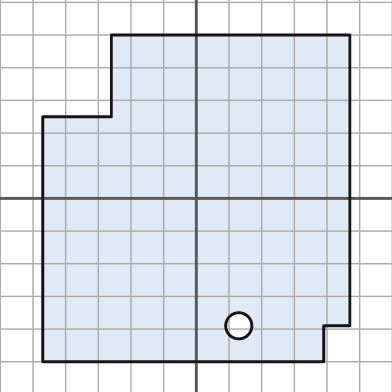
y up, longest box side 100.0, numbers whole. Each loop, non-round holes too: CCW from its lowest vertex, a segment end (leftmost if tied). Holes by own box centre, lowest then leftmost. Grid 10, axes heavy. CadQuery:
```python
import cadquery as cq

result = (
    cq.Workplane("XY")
    .moveTo(-47.0, -50.0)
    .lineTo(39.0, -50.0)
    .lineTo(39.0, -39.0)
    .lineTo(47.0, -39.0)
    .lineTo(47.0, 50.0)
    .lineTo(-26.0, 50.0)
    .lineTo(-26.0, 25.0)
    .lineTo(-47.0, 25.0)
    .close()
    .moveTo(13.0, -39.0)
    .circle(4.0)
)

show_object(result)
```